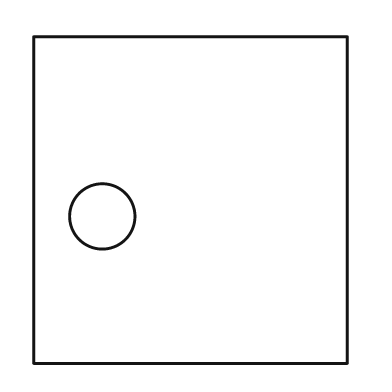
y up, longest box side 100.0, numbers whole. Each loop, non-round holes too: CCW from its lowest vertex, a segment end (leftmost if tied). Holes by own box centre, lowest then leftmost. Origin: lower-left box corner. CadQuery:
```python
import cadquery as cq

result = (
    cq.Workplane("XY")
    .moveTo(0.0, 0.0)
    .lineTo(96.0, 0.0)
    .lineTo(96.0, 100.0)
    .lineTo(0.0, 100.0)
    .close()
    .moveTo(21.0, 45.0)
    .circle(10.0)
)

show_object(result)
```